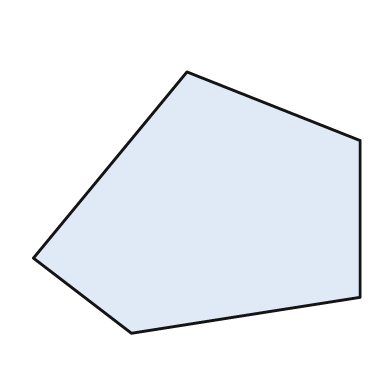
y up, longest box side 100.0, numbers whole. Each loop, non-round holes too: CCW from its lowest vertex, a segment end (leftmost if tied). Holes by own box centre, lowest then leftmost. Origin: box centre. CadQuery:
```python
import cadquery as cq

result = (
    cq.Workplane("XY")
    .moveTo(-20.0, -40.0)
    .lineTo(50.0, -29.0)
    .lineTo(50.0, 19.0)
    .lineTo(-3.0, 40.0)
    .lineTo(-50.0, -17.0)
    .close()
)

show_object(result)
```